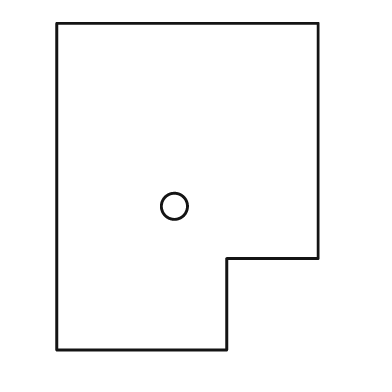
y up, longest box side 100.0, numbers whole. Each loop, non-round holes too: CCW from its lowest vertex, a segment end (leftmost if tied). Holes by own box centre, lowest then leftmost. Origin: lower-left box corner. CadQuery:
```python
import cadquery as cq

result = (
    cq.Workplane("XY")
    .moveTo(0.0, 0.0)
    .lineTo(52.0, 0.0)
    .lineTo(52.0, 28.0)
    .lineTo(80.0, 28.0)
    .lineTo(80.0, 100.0)
    .lineTo(0.0, 100.0)
    .close()
    .moveTo(36.0, 44.0)
    .circle(4.0)
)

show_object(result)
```